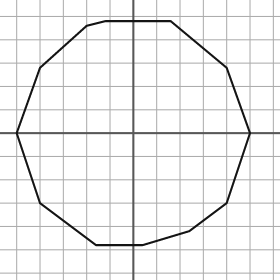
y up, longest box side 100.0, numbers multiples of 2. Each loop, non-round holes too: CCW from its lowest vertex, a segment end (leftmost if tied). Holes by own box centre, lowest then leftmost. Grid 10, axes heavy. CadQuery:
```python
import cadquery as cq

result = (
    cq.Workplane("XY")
    .moveTo(-16.0, -48.0)
    .lineTo(4.0, -48.0)
    .lineTo(24.0, -42.0)
    .lineTo(40.0, -30.0)
    .lineTo(50.0, 0.0)
    .lineTo(40.0, 28.0)
    .lineTo(16.0, 48.0)
    .lineTo(-12.0, 48.0)
    .lineTo(-20.0, 46.0)
    .lineTo(-40.0, 28.0)
    .lineTo(-50.0, 0.0)
    .lineTo(-40.0, -30.0)
    .close()
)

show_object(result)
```